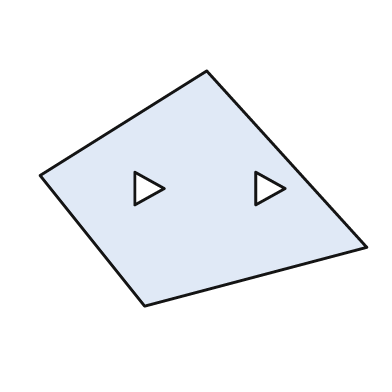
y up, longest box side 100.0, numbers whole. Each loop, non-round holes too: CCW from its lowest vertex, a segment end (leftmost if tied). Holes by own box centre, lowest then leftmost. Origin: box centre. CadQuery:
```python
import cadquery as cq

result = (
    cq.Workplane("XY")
    .moveTo(-18.0, -36.0)
    .lineTo(50.0, -18.0)
    .lineTo(1.0, 36.0)
    .lineTo(-50.0, 4.0)
    .close()
    .moveTo(-21.0, -5.0)
    .lineTo(-12.0, 0.0)
    .lineTo(-21.0, 5.0)
    .close()
    .moveTo(16.0, -5.0)
    .lineTo(25.0, 0.0)
    .lineTo(16.0, 5.0)
    .close()
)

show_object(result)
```